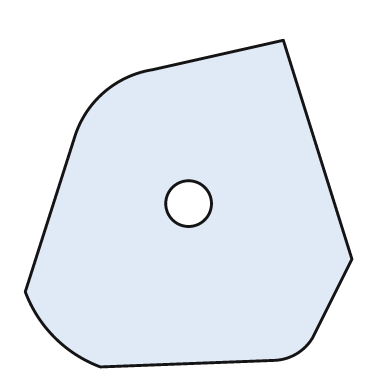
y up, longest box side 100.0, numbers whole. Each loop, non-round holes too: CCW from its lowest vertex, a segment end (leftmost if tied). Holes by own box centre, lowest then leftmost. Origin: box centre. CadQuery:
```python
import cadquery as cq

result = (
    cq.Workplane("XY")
    .moveTo(-27.0, -50.0)
    .lineTo(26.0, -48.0)
    .threePointArc((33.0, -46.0), (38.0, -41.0))
    .lineTo(50.0, -17.0)
    .lineTo(29.0, 50.0)
    .lineTo(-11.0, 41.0)
    .threePointArc((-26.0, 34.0), (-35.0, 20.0))
    .lineTo(-50.0, -27.0)
    .threePointArc((-41.0, -41.0), (-27.0, -50.0))
    .close()
    .moveTo(0.0, 0.0)
    .circle(7.0)
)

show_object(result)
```